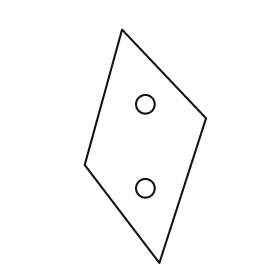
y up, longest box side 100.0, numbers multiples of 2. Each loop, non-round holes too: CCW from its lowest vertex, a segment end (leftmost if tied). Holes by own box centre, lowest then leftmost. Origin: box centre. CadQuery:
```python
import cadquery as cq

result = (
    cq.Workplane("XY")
    .moveTo(6.0, -50.0)
    .lineTo(26.0, 12.0)
    .lineTo(-10.0, 50.0)
    .lineTo(-26.0, -8.0)
    .close()
    .moveTo(0.0, -18.0)
    .circle(4.0)
    .moveTo(0.0, 18.0)
    .circle(4.0)
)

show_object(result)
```